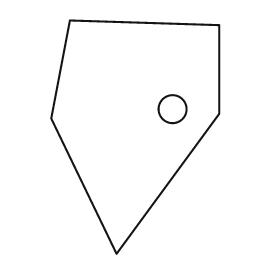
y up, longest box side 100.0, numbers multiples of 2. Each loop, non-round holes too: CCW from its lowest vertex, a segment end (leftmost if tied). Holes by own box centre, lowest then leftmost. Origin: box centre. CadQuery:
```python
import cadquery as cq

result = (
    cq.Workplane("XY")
    .moveTo(-8.0, -50.0)
    .lineTo(36.0, 10.0)
    .lineTo(36.0, 48.0)
    .lineTo(-28.0, 50.0)
    .lineTo(-36.0, 8.0)
    .close()
    .moveTo(16.0, 12.0)
    .circle(6.0)
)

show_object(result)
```